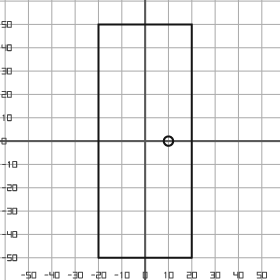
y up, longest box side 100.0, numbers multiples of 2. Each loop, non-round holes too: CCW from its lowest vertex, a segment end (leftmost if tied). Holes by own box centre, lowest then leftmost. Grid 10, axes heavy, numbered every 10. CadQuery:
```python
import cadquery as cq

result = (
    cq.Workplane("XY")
    .moveTo(-20.0, -50.0)
    .lineTo(20.0, -50.0)
    .lineTo(20.0, 50.0)
    .lineTo(-20.0, 50.0)
    .close()
    .moveTo(10.0, 0.0)
    .circle(2.0)
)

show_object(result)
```